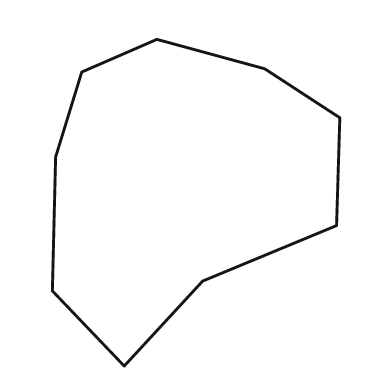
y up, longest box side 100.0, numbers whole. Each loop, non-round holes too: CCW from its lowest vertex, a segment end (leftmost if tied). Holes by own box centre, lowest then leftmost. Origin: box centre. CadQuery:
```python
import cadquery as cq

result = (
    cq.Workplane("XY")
    .moveTo(-22.0, -50.0)
    .lineTo(2.0, -24.0)
    .lineTo(43.0, -7.0)
    .lineTo(44.0, 26.0)
    .lineTo(21.0, 41.0)
    .lineTo(-12.0, 50.0)
    .lineTo(-35.0, 40.0)
    .lineTo(-43.0, 14.0)
    .lineTo(-44.0, -27.0)
    .close()
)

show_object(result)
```